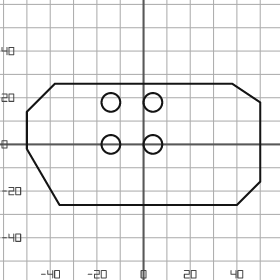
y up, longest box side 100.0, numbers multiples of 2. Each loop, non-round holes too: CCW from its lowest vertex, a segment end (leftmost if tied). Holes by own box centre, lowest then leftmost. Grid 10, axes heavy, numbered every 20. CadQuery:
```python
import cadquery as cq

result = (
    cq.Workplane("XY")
    .moveTo(-36.0, -26.0)
    .lineTo(40.0, -26.0)
    .lineTo(50.0, -16.0)
    .lineTo(50.0, 18.0)
    .lineTo(38.0, 26.0)
    .lineTo(-38.0, 26.0)
    .lineTo(-50.0, 14.0)
    .lineTo(-50.0, -2.0)
    .close()
    .moveTo(-14.0, 0.0)
    .circle(4.0)
    .moveTo(4.0, 0.0)
    .circle(4.0)
    .moveTo(-14.0, 18.0)
    .circle(4.0)
    .moveTo(4.0, 18.0)
    .circle(4.0)
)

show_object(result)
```